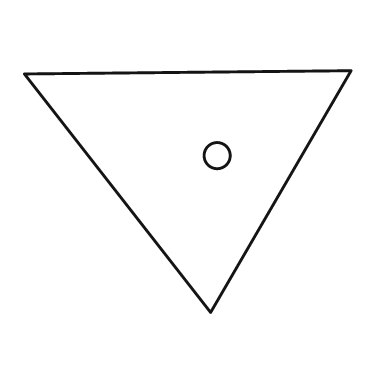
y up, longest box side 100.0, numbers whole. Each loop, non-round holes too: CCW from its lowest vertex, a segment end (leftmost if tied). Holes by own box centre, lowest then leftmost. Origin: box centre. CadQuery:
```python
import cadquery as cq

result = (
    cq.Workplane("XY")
    .moveTo(7.0, -37.0)
    .lineTo(50.0, 37.0)
    .lineTo(-50.0, 36.0)
    .close()
    .moveTo(9.0, 11.0)
    .circle(4.0)
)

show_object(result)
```